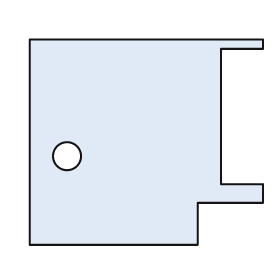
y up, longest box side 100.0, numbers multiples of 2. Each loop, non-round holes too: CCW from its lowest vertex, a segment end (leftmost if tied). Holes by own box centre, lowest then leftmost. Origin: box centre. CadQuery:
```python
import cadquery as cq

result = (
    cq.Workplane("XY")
    .moveTo(-50.0, -44.0)
    .lineTo(22.0, -44.0)
    .lineTo(22.0, -26.0)
    .lineTo(50.0, -26.0)
    .lineTo(50.0, -18.0)
    .lineTo(32.0, -18.0)
    .lineTo(32.0, 40.0)
    .lineTo(50.0, 40.0)
    .lineTo(50.0, 44.0)
    .lineTo(-50.0, 44.0)
    .close()
    .moveTo(-34.0, -6.0)
    .circle(6.0)
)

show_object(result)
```